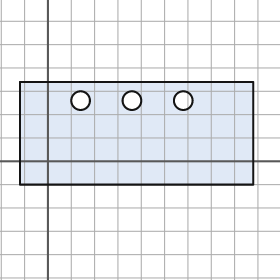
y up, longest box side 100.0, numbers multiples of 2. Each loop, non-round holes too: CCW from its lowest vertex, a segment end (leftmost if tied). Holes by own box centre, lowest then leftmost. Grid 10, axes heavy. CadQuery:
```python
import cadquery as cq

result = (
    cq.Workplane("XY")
    .moveTo(-12.0, -10.0)
    .lineTo(88.0, -10.0)
    .lineTo(88.0, 34.0)
    .lineTo(-12.0, 34.0)
    .close()
    .moveTo(14.0, 26.0)
    .circle(4.0)
    .moveTo(36.0, 26.0)
    .circle(4.0)
    .moveTo(58.0, 26.0)
    .circle(4.0)
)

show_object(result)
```